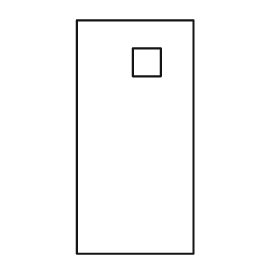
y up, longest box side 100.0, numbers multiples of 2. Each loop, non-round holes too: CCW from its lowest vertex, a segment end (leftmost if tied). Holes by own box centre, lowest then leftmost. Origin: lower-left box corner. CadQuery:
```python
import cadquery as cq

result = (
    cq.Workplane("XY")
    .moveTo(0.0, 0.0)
    .lineTo(50.0, 0.0)
    .lineTo(50.0, 100.0)
    .lineTo(0.0, 100.0)
    .close()
    .moveTo(24.0, 76.0)
    .lineTo(36.0, 76.0)
    .lineTo(36.0, 88.0)
    .lineTo(24.0, 88.0)
    .close()
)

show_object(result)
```